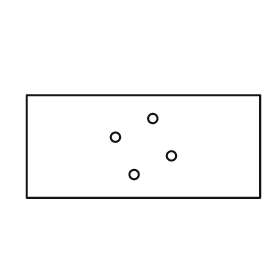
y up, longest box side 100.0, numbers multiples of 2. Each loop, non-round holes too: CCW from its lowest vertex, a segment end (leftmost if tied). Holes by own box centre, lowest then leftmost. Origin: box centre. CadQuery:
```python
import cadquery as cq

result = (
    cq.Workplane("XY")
    .moveTo(-50.0, -22.0)
    .lineTo(50.0, -22.0)
    .lineTo(50.0, 22.0)
    .lineTo(-50.0, 22.0)
    .close()
    .moveTo(-4.0, -12.0)
    .circle(2.0)
    .moveTo(12.0, -4.0)
    .circle(2.0)
    .moveTo(-12.0, 4.0)
    .circle(2.0)
    .moveTo(4.0, 12.0)
    .circle(2.0)
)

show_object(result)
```